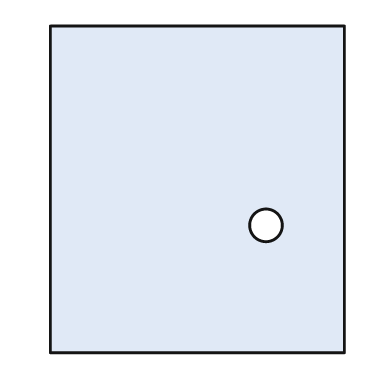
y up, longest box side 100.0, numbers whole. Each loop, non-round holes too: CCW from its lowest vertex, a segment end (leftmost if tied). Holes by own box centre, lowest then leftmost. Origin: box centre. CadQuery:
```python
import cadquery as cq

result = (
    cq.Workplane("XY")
    .moveTo(-45.0, -50.0)
    .lineTo(45.0, -50.0)
    .lineTo(45.0, 50.0)
    .lineTo(-45.0, 50.0)
    .close()
    .moveTo(21.0, -11.0)
    .circle(5.0)
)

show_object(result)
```